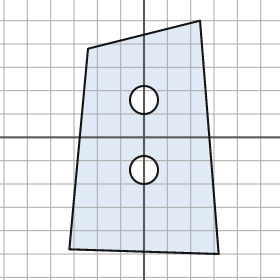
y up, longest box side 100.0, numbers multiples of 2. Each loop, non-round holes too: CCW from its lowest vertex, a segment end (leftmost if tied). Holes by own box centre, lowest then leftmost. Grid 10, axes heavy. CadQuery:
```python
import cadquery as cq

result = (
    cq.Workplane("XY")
    .moveTo(32.0, -50.0)
    .lineTo(24.0, 50.0)
    .lineTo(-24.0, 38.0)
    .lineTo(-32.0, -48.0)
    .close()
    .moveTo(0.0, -14.0)
    .circle(6.0)
    .moveTo(0.0, 16.0)
    .circle(6.0)
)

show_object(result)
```